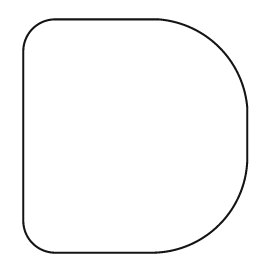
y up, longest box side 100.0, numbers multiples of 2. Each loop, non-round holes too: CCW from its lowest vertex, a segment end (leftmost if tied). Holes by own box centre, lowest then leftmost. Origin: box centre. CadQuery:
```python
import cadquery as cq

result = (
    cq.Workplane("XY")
    .moveTo(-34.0, -50.0)
    .lineTo(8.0, -50.0)
    .threePointArc((36.0, -38.0), (48.0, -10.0))
    .lineTo(48.0, 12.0)
    .threePointArc((36.0, 38.0), (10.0, 50.0))
    .lineTo(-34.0, 50.0)
    .threePointArc((-44.0, 46.0), (-48.0, 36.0))
    .lineTo(-48.0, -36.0)
    .threePointArc((-44.0, -46.0), (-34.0, -50.0))
    .close()
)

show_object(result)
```